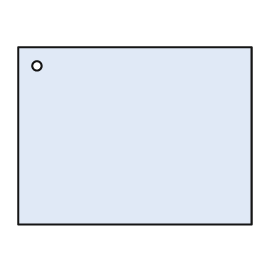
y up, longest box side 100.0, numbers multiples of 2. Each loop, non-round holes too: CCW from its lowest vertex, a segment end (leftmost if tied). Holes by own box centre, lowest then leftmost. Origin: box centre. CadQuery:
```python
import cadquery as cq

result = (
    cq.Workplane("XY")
    .moveTo(-50.0, -38.0)
    .lineTo(50.0, -38.0)
    .lineTo(50.0, 38.0)
    .lineTo(-50.0, 38.0)
    .close()
    .moveTo(-42.0, 30.0)
    .circle(2.0)
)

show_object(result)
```